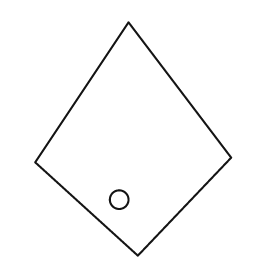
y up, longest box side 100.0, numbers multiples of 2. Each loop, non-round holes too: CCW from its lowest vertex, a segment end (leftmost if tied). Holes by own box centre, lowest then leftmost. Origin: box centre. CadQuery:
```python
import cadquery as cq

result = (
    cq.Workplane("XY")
    .moveTo(2.0, -50.0)
    .lineTo(42.0, -8.0)
    .lineTo(-2.0, 50.0)
    .lineTo(-42.0, -10.0)
    .close()
    .moveTo(-6.0, -26.0)
    .circle(4.0)
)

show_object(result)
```